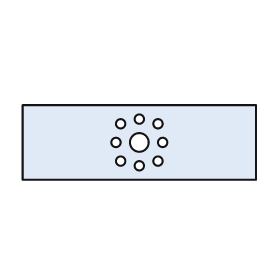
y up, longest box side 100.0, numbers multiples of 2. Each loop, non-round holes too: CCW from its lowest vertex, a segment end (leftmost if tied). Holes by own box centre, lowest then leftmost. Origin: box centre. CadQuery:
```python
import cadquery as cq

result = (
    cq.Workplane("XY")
    .moveTo(-50.0, -16.0)
    .lineTo(50.0, -16.0)
    .lineTo(50.0, 16.0)
    .lineTo(-50.0, 16.0)
    .close()
    .moveTo(0.0, -10.0)
    .circle(2.0)
    .moveTo(-8.0, -8.0)
    .circle(2.0)
    .moveTo(8.0, -8.0)
    .circle(2.0)
    .moveTo(-10.0, 0.0)
    .circle(2.0)
    .moveTo(0.0, 0.0)
    .circle(4.0)
    .moveTo(10.0, 0.0)
    .circle(2.0)
    .moveTo(-8.0, 8.0)
    .circle(2.0)
    .moveTo(8.0, 8.0)
    .circle(2.0)
    .moveTo(0.0, 10.0)
    .circle(2.0)
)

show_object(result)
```